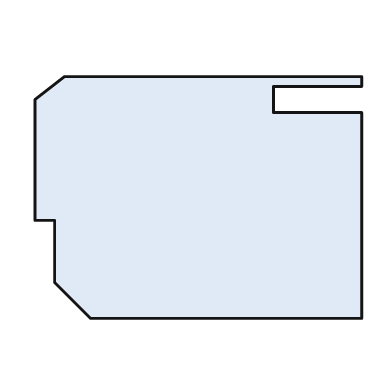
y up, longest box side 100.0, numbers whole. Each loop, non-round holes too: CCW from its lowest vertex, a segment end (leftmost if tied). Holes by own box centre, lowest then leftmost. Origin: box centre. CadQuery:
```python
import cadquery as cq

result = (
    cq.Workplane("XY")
    .moveTo(-33.0, -37.0)
    .lineTo(50.0, -37.0)
    .lineTo(50.0, 26.0)
    .lineTo(23.0, 26.0)
    .lineTo(23.0, 34.0)
    .lineTo(50.0, 34.0)
    .lineTo(50.0, 37.0)
    .lineTo(-41.0, 37.0)
    .lineTo(-50.0, 30.0)
    .lineTo(-50.0, -7.0)
    .lineTo(-44.0, -7.0)
    .lineTo(-44.0, -26.0)
    .close()
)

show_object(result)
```